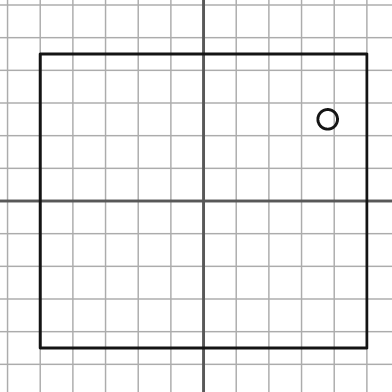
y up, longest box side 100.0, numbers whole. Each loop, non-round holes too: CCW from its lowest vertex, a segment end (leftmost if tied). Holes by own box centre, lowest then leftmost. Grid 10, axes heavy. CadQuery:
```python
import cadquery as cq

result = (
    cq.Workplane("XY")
    .moveTo(-50.0, -45.0)
    .lineTo(50.0, -45.0)
    .lineTo(50.0, 45.0)
    .lineTo(-50.0, 45.0)
    .close()
    .moveTo(38.0, 25.0)
    .circle(3.0)
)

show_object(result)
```